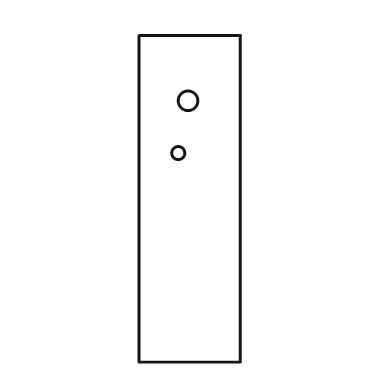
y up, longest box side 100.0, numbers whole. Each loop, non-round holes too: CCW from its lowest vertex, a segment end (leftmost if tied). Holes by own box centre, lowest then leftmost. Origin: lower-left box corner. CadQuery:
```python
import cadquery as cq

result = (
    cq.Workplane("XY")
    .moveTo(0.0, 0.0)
    .lineTo(31.0, 0.0)
    .lineTo(31.0, 100.0)
    .lineTo(0.0, 100.0)
    .close()
    .moveTo(12.0, 64.0)
    .circle(2.0)
    .moveTo(15.0, 80.0)
    .circle(3.0)
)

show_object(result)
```